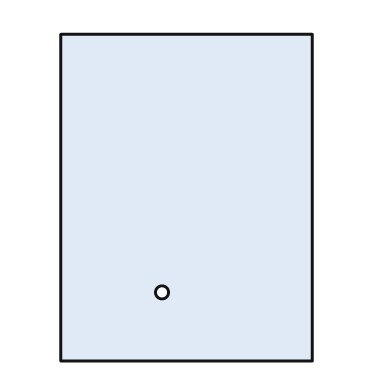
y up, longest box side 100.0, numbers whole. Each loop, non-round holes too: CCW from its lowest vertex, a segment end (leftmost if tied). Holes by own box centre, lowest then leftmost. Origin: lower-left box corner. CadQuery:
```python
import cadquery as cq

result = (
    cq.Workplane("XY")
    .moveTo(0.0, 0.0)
    .lineTo(77.0, 0.0)
    .lineTo(77.0, 100.0)
    .lineTo(0.0, 100.0)
    .close()
    .moveTo(31.0, 21.0)
    .circle(2.0)
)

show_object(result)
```